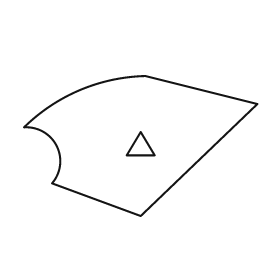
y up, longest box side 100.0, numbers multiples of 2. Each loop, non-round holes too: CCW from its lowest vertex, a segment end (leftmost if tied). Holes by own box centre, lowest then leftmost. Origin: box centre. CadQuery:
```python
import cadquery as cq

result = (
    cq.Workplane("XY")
    .moveTo(0.0, -30.0)
    .lineTo(50.0, 18.0)
    .lineTo(2.0, 30.0)
    .threePointArc((-26.0, 24.0), (-50.0, 8.0))
    .threePointArc((-36.0, 0.0), (-38.0, -16.0))
    .close()
    .moveTo(-6.0, -4.0)
    .lineTo(6.0, -4.0)
    .lineTo(0.0, 6.0)
    .close()
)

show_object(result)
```